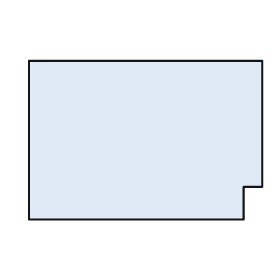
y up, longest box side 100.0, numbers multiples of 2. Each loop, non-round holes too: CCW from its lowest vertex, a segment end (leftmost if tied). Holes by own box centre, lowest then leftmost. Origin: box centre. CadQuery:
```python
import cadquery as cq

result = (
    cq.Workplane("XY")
    .moveTo(-50.0, -34.0)
    .lineTo(42.0, -34.0)
    .lineTo(42.0, -20.0)
    .lineTo(50.0, -20.0)
    .lineTo(50.0, 34.0)
    .lineTo(-50.0, 34.0)
    .close()
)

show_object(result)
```